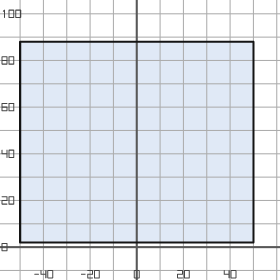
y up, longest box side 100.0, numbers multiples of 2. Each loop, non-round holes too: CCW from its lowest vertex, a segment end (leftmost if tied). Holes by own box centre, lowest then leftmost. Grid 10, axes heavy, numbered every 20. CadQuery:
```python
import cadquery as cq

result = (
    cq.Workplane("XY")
    .moveTo(-50.0, 2.0)
    .lineTo(50.0, 2.0)
    .lineTo(50.0, 88.0)
    .lineTo(-50.0, 88.0)
    .close()
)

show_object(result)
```